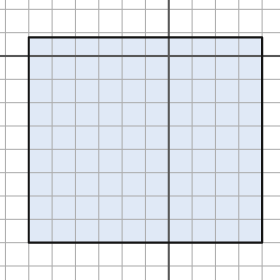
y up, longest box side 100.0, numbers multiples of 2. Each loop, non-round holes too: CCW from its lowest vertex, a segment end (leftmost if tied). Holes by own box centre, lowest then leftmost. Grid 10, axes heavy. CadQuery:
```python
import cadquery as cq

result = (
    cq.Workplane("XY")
    .moveTo(-60.0, -80.0)
    .lineTo(40.0, -80.0)
    .lineTo(40.0, 8.0)
    .lineTo(-60.0, 8.0)
    .close()
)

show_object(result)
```